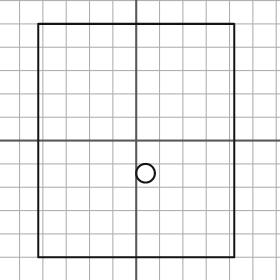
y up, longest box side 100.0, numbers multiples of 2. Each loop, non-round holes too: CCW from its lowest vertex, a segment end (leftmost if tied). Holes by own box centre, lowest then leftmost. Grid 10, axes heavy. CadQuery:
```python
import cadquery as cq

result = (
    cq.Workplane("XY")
    .moveTo(-42.0, -50.0)
    .lineTo(42.0, -50.0)
    .lineTo(42.0, 50.0)
    .lineTo(-42.0, 50.0)
    .close()
    .moveTo(4.0, -14.0)
    .circle(4.0)
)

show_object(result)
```